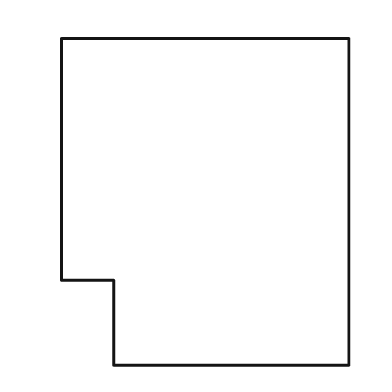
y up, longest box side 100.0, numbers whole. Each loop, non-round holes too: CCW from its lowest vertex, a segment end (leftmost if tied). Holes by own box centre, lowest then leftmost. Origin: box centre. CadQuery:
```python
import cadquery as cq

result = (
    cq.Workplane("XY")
    .moveTo(-28.0, -50.0)
    .lineTo(44.0, -50.0)
    .lineTo(44.0, 50.0)
    .lineTo(-44.0, 50.0)
    .lineTo(-44.0, -24.0)
    .lineTo(-28.0, -24.0)
    .close()
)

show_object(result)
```